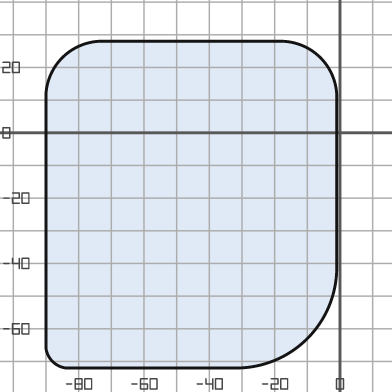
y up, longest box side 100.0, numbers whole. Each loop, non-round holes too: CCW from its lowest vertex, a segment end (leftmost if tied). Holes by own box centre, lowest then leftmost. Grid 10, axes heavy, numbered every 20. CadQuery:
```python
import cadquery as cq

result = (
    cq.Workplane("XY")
    .moveTo(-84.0, -72.0)
    .lineTo(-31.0, -72.0)
    .threePointArc((-10.0, -63.0), (-1.0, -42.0))
    .lineTo(-1.0, 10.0)
    .threePointArc((-6.0, 23.0), (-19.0, 28.0))
    .lineTo(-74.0, 28.0)
    .threePointArc((-85.0, 23.0), (-90.0, 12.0))
    .lineTo(-90.0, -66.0)
    .threePointArc((-88.0, -70.0), (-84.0, -72.0))
    .close()
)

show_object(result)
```